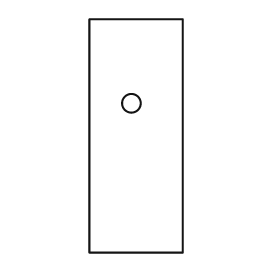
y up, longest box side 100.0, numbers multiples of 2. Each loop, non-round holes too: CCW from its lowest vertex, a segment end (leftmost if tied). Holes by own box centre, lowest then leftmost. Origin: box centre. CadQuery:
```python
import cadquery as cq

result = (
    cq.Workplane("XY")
    .moveTo(-20.0, -50.0)
    .lineTo(20.0, -50.0)
    .lineTo(20.0, 50.0)
    .lineTo(-20.0, 50.0)
    .close()
    .moveTo(-2.0, 14.0)
    .circle(4.0)
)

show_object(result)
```